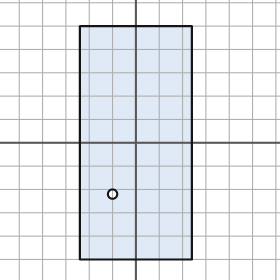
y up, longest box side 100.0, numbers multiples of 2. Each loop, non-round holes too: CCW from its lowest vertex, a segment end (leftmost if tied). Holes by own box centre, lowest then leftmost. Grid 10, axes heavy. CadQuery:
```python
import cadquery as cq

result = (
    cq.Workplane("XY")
    .moveTo(-24.0, -50.0)
    .lineTo(24.0, -50.0)
    .lineTo(24.0, 50.0)
    .lineTo(-24.0, 50.0)
    .close()
    .moveTo(-10.0, -22.0)
    .circle(2.0)
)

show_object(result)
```